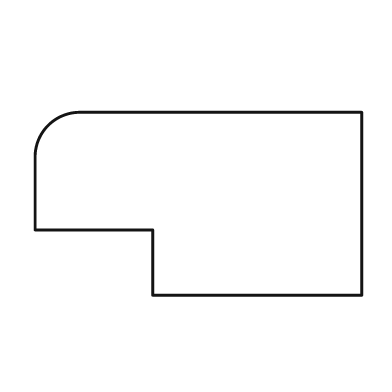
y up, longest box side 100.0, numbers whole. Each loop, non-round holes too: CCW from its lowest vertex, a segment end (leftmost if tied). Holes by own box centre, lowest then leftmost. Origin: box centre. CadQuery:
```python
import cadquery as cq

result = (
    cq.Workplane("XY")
    .moveTo(-14.0, -28.0)
    .lineTo(50.0, -28.0)
    .lineTo(50.0, 28.0)
    .lineTo(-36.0, 28.0)
    .threePointArc((-46.0, 24.0), (-50.0, 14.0))
    .lineTo(-50.0, -8.0)
    .lineTo(-14.0, -8.0)
    .close()
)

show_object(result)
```